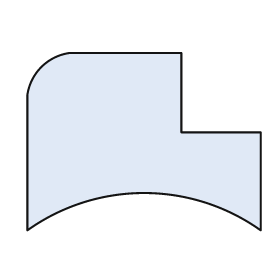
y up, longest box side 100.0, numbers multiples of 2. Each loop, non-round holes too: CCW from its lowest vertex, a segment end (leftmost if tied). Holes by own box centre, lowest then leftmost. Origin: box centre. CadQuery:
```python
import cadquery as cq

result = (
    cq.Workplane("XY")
    .moveTo(-50.0, -38.0)
    .threePointArc((0.0, -22.0), (50.0, -38.0))
    .lineTo(50.0, 4.0)
    .lineTo(16.0, 4.0)
    .lineTo(16.0, 38.0)
    .lineTo(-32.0, 38.0)
    .threePointArc((-44.0, 32.0), (-50.0, 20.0))
    .close()
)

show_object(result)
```